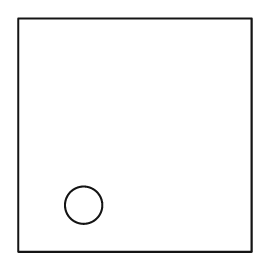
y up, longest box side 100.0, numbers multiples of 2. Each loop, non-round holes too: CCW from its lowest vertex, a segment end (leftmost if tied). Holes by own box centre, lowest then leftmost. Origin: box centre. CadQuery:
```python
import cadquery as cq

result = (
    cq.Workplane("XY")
    .moveTo(-50.0, -50.0)
    .lineTo(50.0, -50.0)
    .lineTo(50.0, 50.0)
    .lineTo(-50.0, 50.0)
    .close()
    .moveTo(-22.0, -30.0)
    .circle(8.0)
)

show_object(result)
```